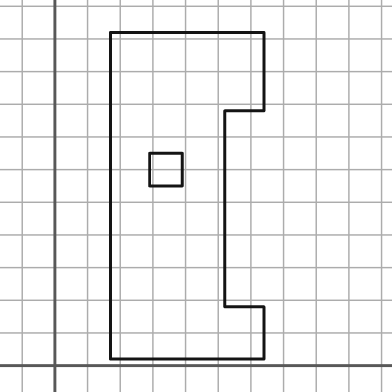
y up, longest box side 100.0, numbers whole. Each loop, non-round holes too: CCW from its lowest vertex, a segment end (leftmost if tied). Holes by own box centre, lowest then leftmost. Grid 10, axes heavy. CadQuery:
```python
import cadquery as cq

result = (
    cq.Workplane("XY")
    .moveTo(17.0, 2.0)
    .lineTo(64.0, 2.0)
    .lineTo(64.0, 18.0)
    .lineTo(52.0, 18.0)
    .lineTo(52.0, 78.0)
    .lineTo(64.0, 78.0)
    .lineTo(64.0, 102.0)
    .lineTo(17.0, 102.0)
    .close()
    .moveTo(29.0, 55.0)
    .lineTo(39.0, 55.0)
    .lineTo(39.0, 65.0)
    .lineTo(29.0, 65.0)
    .close()
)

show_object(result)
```